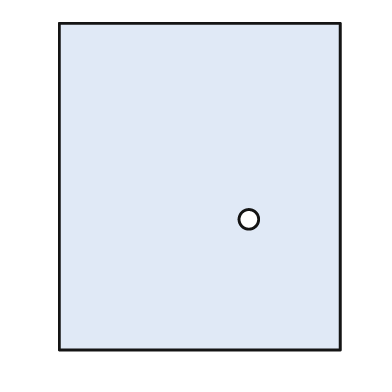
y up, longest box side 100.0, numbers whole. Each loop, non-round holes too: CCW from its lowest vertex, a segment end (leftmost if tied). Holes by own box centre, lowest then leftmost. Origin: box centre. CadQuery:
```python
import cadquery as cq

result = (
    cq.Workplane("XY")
    .moveTo(-43.0, -50.0)
    .lineTo(43.0, -50.0)
    .lineTo(43.0, 50.0)
    .lineTo(-43.0, 50.0)
    .close()
    .moveTo(15.0, -10.0)
    .circle(3.0)
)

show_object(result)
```